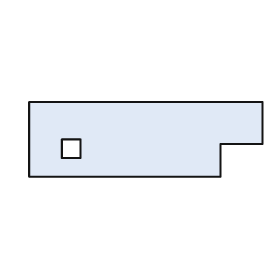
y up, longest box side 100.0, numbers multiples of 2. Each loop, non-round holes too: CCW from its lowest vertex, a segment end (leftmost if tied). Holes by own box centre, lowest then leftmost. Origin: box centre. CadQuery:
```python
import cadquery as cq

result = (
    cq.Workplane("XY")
    .moveTo(-50.0, -16.0)
    .lineTo(32.0, -16.0)
    .lineTo(32.0, -2.0)
    .lineTo(50.0, -2.0)
    .lineTo(50.0, 16.0)
    .lineTo(-50.0, 16.0)
    .close()
    .moveTo(-36.0, -8.0)
    .lineTo(-28.0, -8.0)
    .lineTo(-28.0, 0.0)
    .lineTo(-36.0, 0.0)
    .close()
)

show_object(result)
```